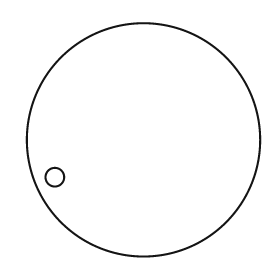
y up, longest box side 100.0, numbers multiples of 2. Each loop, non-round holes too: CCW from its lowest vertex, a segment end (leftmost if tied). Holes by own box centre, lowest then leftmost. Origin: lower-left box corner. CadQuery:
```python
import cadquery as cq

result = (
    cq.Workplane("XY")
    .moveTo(50.0, 50.0)
    .circle(50.0)
    .moveTo(12.0, 34.0)
    .circle(4.0)
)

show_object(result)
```